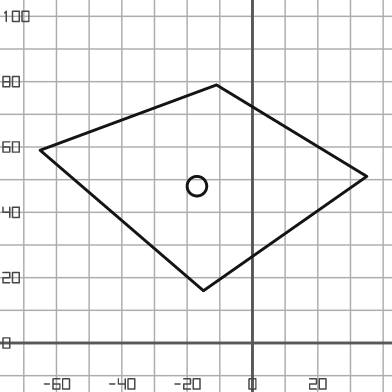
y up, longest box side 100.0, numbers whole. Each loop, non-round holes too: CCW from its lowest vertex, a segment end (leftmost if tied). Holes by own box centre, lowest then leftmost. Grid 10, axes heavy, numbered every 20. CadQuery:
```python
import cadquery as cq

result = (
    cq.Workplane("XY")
    .moveTo(-15.0, 16.0)
    .lineTo(35.0, 51.0)
    .lineTo(-11.0, 79.0)
    .lineTo(-65.0, 59.0)
    .close()
    .moveTo(-17.0, 48.0)
    .circle(3.0)
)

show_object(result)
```